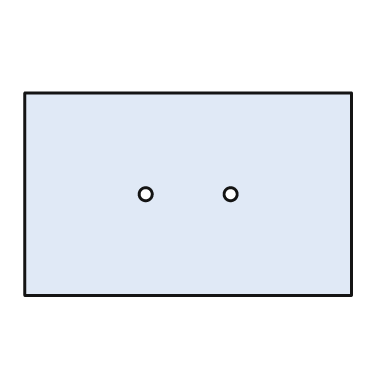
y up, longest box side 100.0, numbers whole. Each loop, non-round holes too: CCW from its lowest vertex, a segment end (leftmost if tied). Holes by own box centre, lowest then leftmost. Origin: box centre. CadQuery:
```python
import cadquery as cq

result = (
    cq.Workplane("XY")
    .moveTo(-50.0, -31.0)
    .lineTo(50.0, -31.0)
    .lineTo(50.0, 31.0)
    .lineTo(-50.0, 31.0)
    .close()
    .moveTo(-13.0, 0.0)
    .circle(2.0)
    .moveTo(13.0, 0.0)
    .circle(2.0)
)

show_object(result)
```